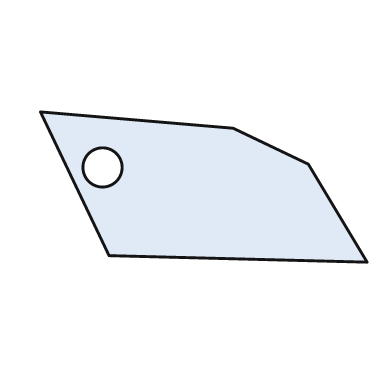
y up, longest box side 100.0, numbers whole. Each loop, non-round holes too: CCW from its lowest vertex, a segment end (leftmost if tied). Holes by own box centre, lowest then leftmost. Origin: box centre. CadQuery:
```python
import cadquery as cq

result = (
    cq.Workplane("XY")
    .moveTo(50.0, -23.0)
    .lineTo(32.0, 7.0)
    .lineTo(9.0, 18.0)
    .lineTo(-50.0, 23.0)
    .lineTo(-29.0, -21.0)
    .close()
    .moveTo(-31.0, 6.0)
    .circle(6.0)
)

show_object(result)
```